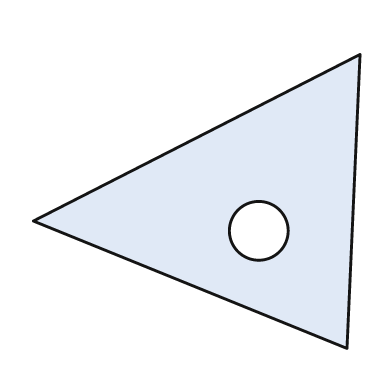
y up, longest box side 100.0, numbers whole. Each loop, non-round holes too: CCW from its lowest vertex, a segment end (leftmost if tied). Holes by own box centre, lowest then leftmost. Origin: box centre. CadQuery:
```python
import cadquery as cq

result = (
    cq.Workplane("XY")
    .moveTo(46.0, -45.0)
    .lineTo(50.0, 45.0)
    .lineTo(-50.0, -6.0)
    .close()
    .moveTo(19.0, -9.0)
    .circle(9.0)
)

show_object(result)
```